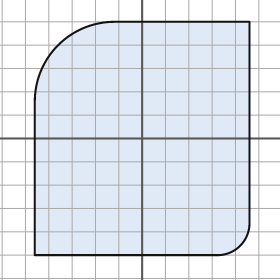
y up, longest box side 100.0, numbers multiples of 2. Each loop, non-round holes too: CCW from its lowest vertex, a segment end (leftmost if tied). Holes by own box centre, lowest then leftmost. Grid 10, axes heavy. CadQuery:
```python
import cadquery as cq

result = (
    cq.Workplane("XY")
    .moveTo(-46.0, -50.0)
    .lineTo(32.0, -50.0)
    .threePointArc((42.0, -46.0), (46.0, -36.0))
    .lineTo(46.0, 50.0)
    .lineTo(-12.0, 50.0)
    .threePointArc((-36.0, 40.0), (-46.0, 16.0))
    .close()
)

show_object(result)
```